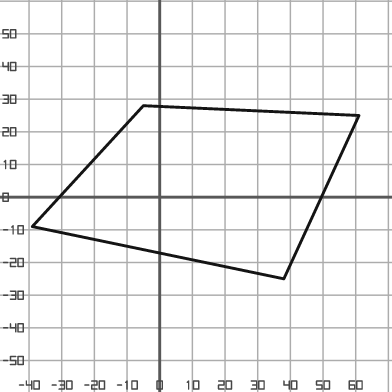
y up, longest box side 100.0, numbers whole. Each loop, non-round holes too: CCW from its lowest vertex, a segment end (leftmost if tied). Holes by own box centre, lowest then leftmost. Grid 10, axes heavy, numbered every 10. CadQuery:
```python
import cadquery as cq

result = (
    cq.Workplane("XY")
    .moveTo(38.0, -25.0)
    .lineTo(61.0, 25.0)
    .lineTo(-5.0, 28.0)
    .lineTo(-39.0, -9.0)
    .close()
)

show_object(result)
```